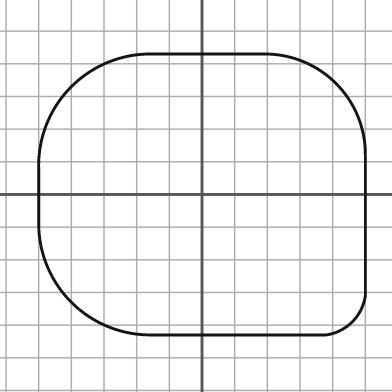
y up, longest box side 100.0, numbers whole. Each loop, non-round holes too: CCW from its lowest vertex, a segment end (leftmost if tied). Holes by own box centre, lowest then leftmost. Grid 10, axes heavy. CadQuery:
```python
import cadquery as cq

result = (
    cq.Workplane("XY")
    .moveTo(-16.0, -43.0)
    .lineTo(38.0, -43.0)
    .threePointArc((46.0, -39.0), (50.0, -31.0))
    .lineTo(50.0, 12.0)
    .threePointArc((41.0, 34.0), (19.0, 43.0))
    .lineTo(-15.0, 43.0)
    .threePointArc((-40.0, 33.0), (-50.0, 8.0))
    .lineTo(-50.0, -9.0)
    .threePointArc((-40.0, -33.0), (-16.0, -43.0))
    .close()
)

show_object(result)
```